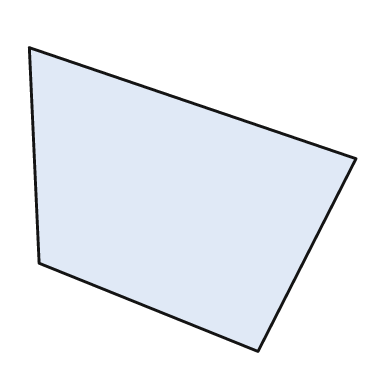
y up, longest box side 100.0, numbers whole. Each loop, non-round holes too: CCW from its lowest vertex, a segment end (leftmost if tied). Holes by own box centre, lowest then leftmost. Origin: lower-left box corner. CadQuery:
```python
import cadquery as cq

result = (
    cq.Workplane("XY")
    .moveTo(70.0, 0.0)
    .lineTo(100.0, 59.0)
    .lineTo(0.0, 93.0)
    .lineTo(3.0, 27.0)
    .close()
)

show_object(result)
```